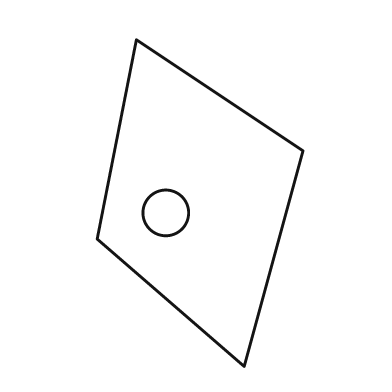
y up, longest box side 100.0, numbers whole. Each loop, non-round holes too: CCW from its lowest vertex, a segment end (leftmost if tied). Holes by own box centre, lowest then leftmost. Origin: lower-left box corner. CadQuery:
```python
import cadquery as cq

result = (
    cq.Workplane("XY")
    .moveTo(45.0, 0.0)
    .lineTo(63.0, 66.0)
    .lineTo(12.0, 100.0)
    .lineTo(0.0, 39.0)
    .close()
    .moveTo(21.0, 47.0)
    .circle(7.0)
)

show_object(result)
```